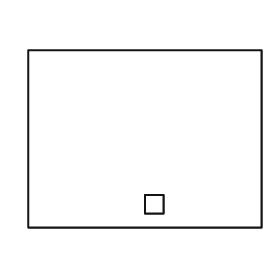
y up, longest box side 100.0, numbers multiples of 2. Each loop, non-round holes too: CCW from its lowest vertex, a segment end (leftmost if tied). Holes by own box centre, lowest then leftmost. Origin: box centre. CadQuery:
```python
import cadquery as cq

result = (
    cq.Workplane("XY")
    .moveTo(-50.0, -38.0)
    .lineTo(50.0, -38.0)
    .lineTo(50.0, 38.0)
    .lineTo(-50.0, 38.0)
    .close()
    .moveTo(0.0, -32.0)
    .lineTo(8.0, -32.0)
    .lineTo(8.0, -24.0)
    .lineTo(0.0, -24.0)
    .close()
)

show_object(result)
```